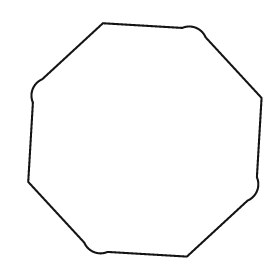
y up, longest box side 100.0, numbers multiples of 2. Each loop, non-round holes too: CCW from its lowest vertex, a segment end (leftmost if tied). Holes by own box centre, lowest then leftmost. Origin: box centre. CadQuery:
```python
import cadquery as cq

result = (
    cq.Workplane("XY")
    .moveTo(18.0, -50.0)
    .lineTo(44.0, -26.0)
    .threePointArc((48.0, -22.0), (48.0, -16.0))
    .lineTo(50.0, 18.0)
    .lineTo(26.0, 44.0)
    .threePointArc((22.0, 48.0), (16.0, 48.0))
    .lineTo(-18.0, 50.0)
    .lineTo(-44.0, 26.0)
    .threePointArc((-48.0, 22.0), (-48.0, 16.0))
    .lineTo(-50.0, -18.0)
    .lineTo(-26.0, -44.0)
    .threePointArc((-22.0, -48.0), (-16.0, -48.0))
    .close()
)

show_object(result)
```